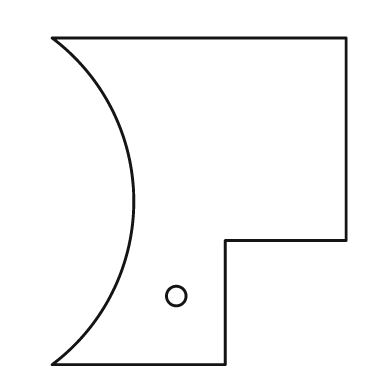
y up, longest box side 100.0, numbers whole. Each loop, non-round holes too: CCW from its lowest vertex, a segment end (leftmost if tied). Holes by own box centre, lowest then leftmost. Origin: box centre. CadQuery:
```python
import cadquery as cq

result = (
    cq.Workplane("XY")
    .moveTo(-45.0, -50.0)
    .lineTo(8.0, -50.0)
    .lineTo(8.0, -12.0)
    .lineTo(45.0, -12.0)
    .lineTo(45.0, 50.0)
    .lineTo(-45.0, 50.0)
    .threePointArc((-20.0, 0.0), (-45.0, -50.0))
    .close()
    .moveTo(-7.0, -29.0)
    .circle(3.0)
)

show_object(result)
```